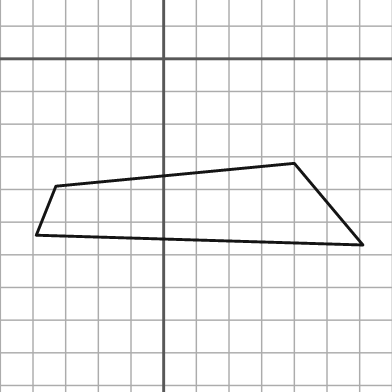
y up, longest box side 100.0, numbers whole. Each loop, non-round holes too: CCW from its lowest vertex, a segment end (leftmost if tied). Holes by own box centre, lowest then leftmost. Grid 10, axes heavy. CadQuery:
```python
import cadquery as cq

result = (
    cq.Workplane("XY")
    .moveTo(61.0, -57.0)
    .lineTo(40.0, -32.0)
    .lineTo(-33.0, -39.0)
    .lineTo(-39.0, -54.0)
    .close()
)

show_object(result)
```